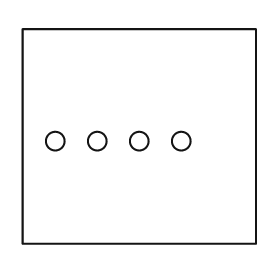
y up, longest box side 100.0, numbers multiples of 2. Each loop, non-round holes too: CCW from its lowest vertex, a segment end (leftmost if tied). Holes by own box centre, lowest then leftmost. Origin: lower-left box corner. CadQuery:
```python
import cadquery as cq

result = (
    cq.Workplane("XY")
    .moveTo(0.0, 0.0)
    .lineTo(100.0, 0.0)
    .lineTo(100.0, 92.0)
    .lineTo(0.0, 92.0)
    .close()
    .moveTo(14.0, 44.0)
    .circle(4.0)
    .moveTo(32.0, 44.0)
    .circle(4.0)
    .moveTo(50.0, 44.0)
    .circle(4.0)
    .moveTo(68.0, 44.0)
    .circle(4.0)
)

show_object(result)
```